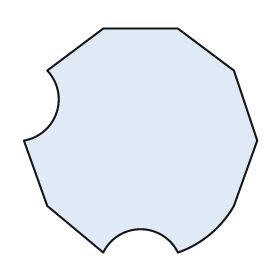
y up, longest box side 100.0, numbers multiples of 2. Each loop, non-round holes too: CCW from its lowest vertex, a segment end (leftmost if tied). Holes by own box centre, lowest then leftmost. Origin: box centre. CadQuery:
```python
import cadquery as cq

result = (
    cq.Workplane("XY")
    .moveTo(-16.0, -48.0)
    .threePointArc((0.0, -38.0), (16.0, -48.0))
    .threePointArc((30.0, -40.0), (40.0, -28.0))
    .lineTo(50.0, 0.0)
    .lineTo(40.0, 30.0)
    .lineTo(16.0, 48.0)
    .lineTo(-16.0, 48.0)
    .lineTo(-40.0, 30.0)
    .threePointArc((-36.0, 12.0), (-50.0, 0.0))
    .lineTo(-40.0, -28.0)
    .close()
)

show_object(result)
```